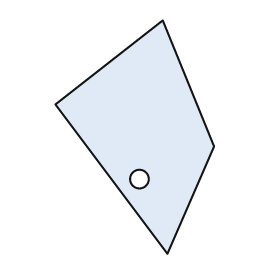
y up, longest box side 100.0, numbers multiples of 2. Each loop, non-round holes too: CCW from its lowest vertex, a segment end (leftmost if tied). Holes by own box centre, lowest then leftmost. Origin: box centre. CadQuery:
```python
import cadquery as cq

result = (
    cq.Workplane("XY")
    .moveTo(14.0, -50.0)
    .lineTo(34.0, -4.0)
    .lineTo(12.0, 50.0)
    .lineTo(-34.0, 14.0)
    .close()
    .moveTo(2.0, -18.0)
    .circle(4.0)
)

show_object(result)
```